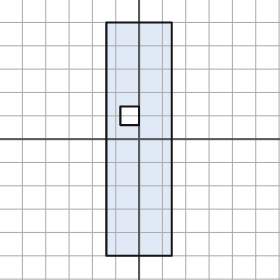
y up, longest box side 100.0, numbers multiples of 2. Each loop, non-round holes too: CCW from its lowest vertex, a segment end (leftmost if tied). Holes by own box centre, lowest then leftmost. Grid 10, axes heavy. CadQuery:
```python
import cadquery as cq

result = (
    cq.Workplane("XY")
    .moveTo(-14.0, -50.0)
    .lineTo(14.0, -50.0)
    .lineTo(14.0, 50.0)
    .lineTo(-14.0, 50.0)
    .close()
    .moveTo(-8.0, 6.0)
    .lineTo(0.0, 6.0)
    .lineTo(0.0, 14.0)
    .lineTo(-8.0, 14.0)
    .close()
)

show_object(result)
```